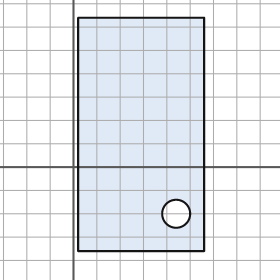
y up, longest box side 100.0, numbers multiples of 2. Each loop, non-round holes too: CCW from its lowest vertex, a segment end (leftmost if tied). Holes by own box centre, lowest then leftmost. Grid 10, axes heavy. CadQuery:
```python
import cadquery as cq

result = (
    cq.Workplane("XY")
    .moveTo(2.0, -36.0)
    .lineTo(56.0, -36.0)
    .lineTo(56.0, 64.0)
    .lineTo(2.0, 64.0)
    .close()
    .moveTo(44.0, -20.0)
    .circle(6.0)
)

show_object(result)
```